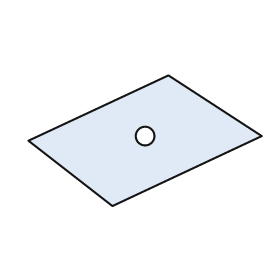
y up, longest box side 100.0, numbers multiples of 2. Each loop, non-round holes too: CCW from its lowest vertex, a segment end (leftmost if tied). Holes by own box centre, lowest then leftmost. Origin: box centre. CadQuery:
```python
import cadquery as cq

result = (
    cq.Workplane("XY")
    .moveTo(-14.0, -28.0)
    .lineTo(50.0, 2.0)
    .lineTo(10.0, 28.0)
    .lineTo(-50.0, 0.0)
    .close()
    .moveTo(0.0, 2.0)
    .circle(4.0)
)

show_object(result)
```